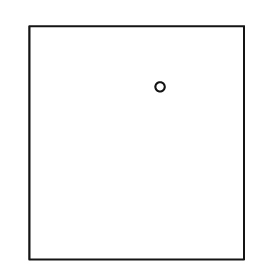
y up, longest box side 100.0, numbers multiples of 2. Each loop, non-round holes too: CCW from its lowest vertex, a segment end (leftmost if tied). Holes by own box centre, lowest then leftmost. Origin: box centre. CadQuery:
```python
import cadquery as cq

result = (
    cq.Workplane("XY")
    .moveTo(-46.0, -50.0)
    .lineTo(46.0, -50.0)
    .lineTo(46.0, 50.0)
    .lineTo(-46.0, 50.0)
    .close()
    .moveTo(10.0, 24.0)
    .circle(2.0)
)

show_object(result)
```